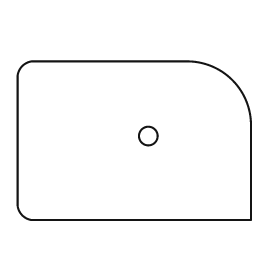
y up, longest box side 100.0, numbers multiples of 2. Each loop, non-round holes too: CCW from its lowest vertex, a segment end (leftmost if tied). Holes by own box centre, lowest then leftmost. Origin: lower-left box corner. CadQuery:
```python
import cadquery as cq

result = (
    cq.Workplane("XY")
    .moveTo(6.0, 0.0)
    .lineTo(100.0, 0.0)
    .lineTo(100.0, 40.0)
    .threePointArc((92.0, 60.0), (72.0, 68.0))
    .lineTo(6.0, 68.0)
    .threePointArc((2.0, 66.0), (0.0, 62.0))
    .lineTo(0.0, 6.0)
    .threePointArc((2.0, 2.0), (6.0, 0.0))
    .close()
    .moveTo(56.0, 36.0)
    .circle(4.0)
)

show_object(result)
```